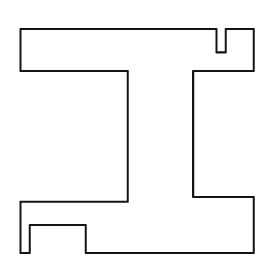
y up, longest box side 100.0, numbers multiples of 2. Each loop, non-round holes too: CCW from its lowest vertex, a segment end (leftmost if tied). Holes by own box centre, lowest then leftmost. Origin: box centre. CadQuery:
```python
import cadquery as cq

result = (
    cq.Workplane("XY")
    .moveTo(-50.0, -48.0)
    .lineTo(-46.0, -48.0)
    .lineTo(-46.0, -36.0)
    .lineTo(-22.0, -36.0)
    .lineTo(-22.0, -48.0)
    .lineTo(50.0, -48.0)
    .lineTo(50.0, -24.0)
    .lineTo(24.0, -24.0)
    .lineTo(24.0, 30.0)
    .lineTo(50.0, 30.0)
    .lineTo(50.0, 48.0)
    .lineTo(38.0, 48.0)
    .lineTo(38.0, 38.0)
    .lineTo(34.0, 38.0)
    .lineTo(34.0, 48.0)
    .lineTo(-50.0, 48.0)
    .lineTo(-50.0, 30.0)
    .lineTo(-4.0, 30.0)
    .lineTo(-4.0, -26.0)
    .lineTo(-50.0, -26.0)
    .close()
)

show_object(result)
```